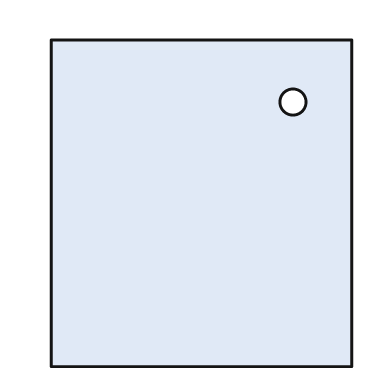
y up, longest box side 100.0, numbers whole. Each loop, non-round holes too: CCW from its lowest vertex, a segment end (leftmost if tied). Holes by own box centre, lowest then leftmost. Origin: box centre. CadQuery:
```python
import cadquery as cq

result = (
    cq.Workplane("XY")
    .moveTo(-46.0, -50.0)
    .lineTo(46.0, -50.0)
    .lineTo(46.0, 50.0)
    .lineTo(-46.0, 50.0)
    .close()
    .moveTo(28.0, 31.0)
    .circle(4.0)
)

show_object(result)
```